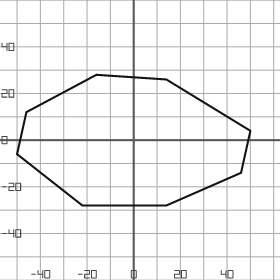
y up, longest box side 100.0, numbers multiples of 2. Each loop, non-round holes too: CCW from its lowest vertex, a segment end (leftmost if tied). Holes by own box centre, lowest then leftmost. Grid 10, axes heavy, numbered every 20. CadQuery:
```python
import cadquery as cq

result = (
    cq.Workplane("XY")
    .moveTo(-22.0, -28.0)
    .lineTo(14.0, -28.0)
    .lineTo(46.0, -14.0)
    .lineTo(50.0, 4.0)
    .lineTo(14.0, 26.0)
    .lineTo(-16.0, 28.0)
    .lineTo(-46.0, 12.0)
    .lineTo(-50.0, -6.0)
    .close()
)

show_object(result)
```